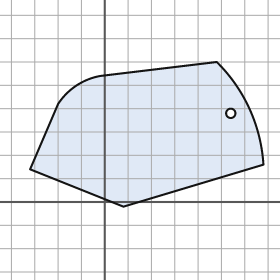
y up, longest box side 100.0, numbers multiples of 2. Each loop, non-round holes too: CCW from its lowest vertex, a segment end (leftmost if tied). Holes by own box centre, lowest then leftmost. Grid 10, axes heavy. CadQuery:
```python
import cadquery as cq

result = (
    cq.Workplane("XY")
    .moveTo(8.0, -2.0)
    .lineTo(68.0, 16.0)
    .threePointArc((62.0, 40.0), (48.0, 60.0))
    .lineTo(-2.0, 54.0)
    .threePointArc((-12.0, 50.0), (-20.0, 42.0))
    .lineTo(-32.0, 14.0)
    .close()
    .moveTo(54.0, 38.0)
    .circle(2.0)
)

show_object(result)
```